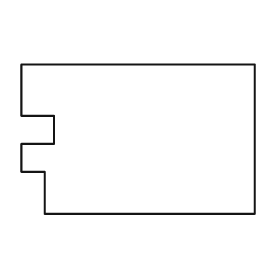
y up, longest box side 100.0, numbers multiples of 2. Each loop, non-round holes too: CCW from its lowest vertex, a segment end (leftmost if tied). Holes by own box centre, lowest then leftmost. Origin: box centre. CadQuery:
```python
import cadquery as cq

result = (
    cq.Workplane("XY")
    .moveTo(-40.0, -32.0)
    .lineTo(50.0, -32.0)
    .lineTo(50.0, 32.0)
    .lineTo(-50.0, 32.0)
    .lineTo(-50.0, 10.0)
    .lineTo(-36.0, 10.0)
    .lineTo(-36.0, -2.0)
    .lineTo(-50.0, -2.0)
    .lineTo(-50.0, -14.0)
    .lineTo(-40.0, -14.0)
    .close()
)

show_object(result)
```